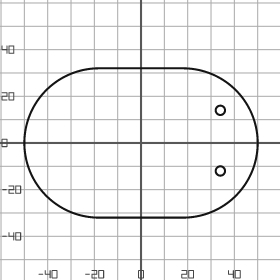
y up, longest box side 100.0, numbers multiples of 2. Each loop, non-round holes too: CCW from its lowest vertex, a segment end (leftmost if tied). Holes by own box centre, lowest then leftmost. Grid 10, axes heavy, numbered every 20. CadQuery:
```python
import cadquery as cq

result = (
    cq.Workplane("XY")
    .moveTo(-18.0, -32.0)
    .lineTo(18.0, -32.0)
    .threePointArc((50.0, 0.0), (18.0, 32.0))
    .lineTo(-18.0, 32.0)
    .threePointArc((-50.0, 0.0), (-18.0, -32.0))
    .close()
    .moveTo(34.0, -12.0)
    .circle(2.0)
    .moveTo(34.0, 14.0)
    .circle(2.0)
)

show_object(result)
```